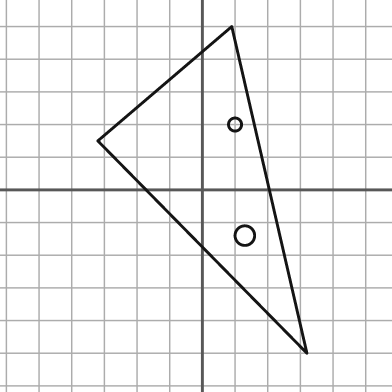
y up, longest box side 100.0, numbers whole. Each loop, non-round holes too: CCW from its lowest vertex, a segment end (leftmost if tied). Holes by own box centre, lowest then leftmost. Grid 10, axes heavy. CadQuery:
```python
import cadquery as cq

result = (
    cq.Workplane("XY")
    .moveTo(32.0, -50.0)
    .lineTo(9.0, 50.0)
    .lineTo(-32.0, 15.0)
    .close()
    .moveTo(13.0, -14.0)
    .circle(3.0)
    .moveTo(10.0, 20.0)
    .circle(2.0)
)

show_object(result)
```